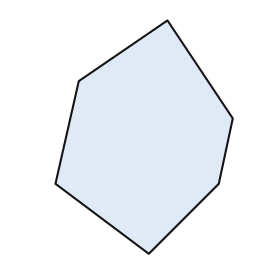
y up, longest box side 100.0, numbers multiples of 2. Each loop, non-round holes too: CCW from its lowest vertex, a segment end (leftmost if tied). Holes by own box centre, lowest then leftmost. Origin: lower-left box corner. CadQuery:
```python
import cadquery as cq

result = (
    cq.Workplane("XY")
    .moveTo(40.0, 0.0)
    .lineTo(70.0, 30.0)
    .lineTo(76.0, 58.0)
    .lineTo(48.0, 100.0)
    .lineTo(10.0, 74.0)
    .lineTo(0.0, 30.0)
    .close()
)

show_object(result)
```